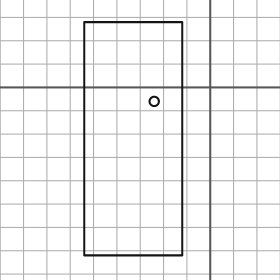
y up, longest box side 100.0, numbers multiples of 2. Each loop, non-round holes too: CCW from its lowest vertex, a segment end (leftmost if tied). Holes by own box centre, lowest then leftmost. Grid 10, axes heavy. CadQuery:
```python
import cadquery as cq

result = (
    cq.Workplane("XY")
    .moveTo(-54.0, -72.0)
    .lineTo(-12.0, -72.0)
    .lineTo(-12.0, 28.0)
    .lineTo(-54.0, 28.0)
    .close()
    .moveTo(-24.0, -6.0)
    .circle(2.0)
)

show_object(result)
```